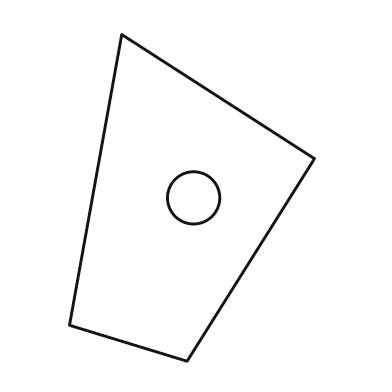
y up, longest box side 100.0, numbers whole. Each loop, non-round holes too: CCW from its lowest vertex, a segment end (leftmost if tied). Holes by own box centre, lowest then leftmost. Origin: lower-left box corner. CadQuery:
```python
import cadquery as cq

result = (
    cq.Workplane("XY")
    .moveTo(36.0, 0.0)
    .lineTo(75.0, 62.0)
    .lineTo(16.0, 100.0)
    .lineTo(0.0, 11.0)
    .close()
    .moveTo(38.0, 50.0)
    .circle(8.0)
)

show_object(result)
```